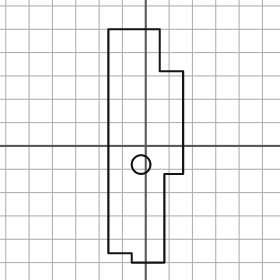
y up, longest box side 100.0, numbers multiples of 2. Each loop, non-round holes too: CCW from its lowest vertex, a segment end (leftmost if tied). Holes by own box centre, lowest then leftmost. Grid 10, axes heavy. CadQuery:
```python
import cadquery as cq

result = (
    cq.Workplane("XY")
    .moveTo(-6.0, -50.0)
    .lineTo(8.0, -50.0)
    .lineTo(8.0, -12.0)
    .lineTo(16.0, -12.0)
    .lineTo(16.0, 32.0)
    .lineTo(6.0, 32.0)
    .lineTo(6.0, 50.0)
    .lineTo(-16.0, 50.0)
    .lineTo(-16.0, -46.0)
    .lineTo(-6.0, -46.0)
    .close()
    .moveTo(-2.0, -8.0)
    .circle(4.0)
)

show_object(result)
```